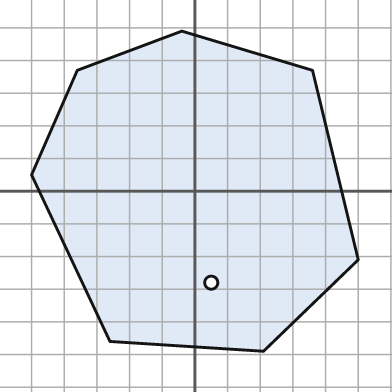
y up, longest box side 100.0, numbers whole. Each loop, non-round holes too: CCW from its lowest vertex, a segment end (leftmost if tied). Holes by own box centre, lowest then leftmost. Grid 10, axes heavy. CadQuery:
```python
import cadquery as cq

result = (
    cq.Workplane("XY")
    .moveTo(21.0, -49.0)
    .lineTo(50.0, -21.0)
    .lineTo(36.0, 37.0)
    .lineTo(-4.0, 49.0)
    .lineTo(-36.0, 37.0)
    .lineTo(-50.0, 5.0)
    .lineTo(-26.0, -46.0)
    .close()
    .moveTo(5.0, -28.0)
    .circle(2.0)
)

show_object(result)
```